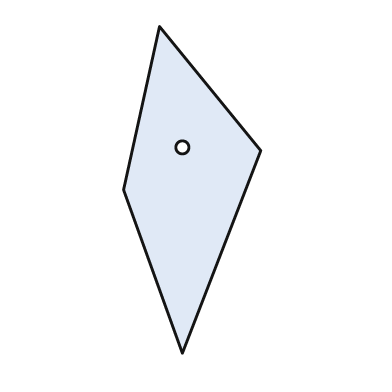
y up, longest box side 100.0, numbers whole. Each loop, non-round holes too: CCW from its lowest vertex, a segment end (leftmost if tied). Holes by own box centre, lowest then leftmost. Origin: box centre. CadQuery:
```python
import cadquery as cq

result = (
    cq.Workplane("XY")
    .moveTo(-3.0, -50.0)
    .lineTo(21.0, 12.0)
    .lineTo(-10.0, 50.0)
    .lineTo(-21.0, 0.0)
    .close()
    .moveTo(-3.0, 13.0)
    .circle(2.0)
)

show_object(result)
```